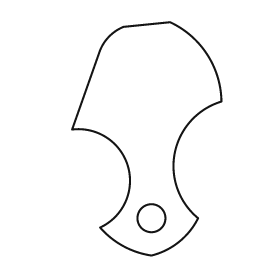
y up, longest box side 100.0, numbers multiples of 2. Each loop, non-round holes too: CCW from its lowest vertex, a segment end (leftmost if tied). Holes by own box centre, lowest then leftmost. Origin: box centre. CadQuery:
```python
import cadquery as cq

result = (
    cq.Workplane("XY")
    .moveTo(2.0, -50.0)
    .threePointArc((14.0, -44.0), (22.0, -34.0))
    .threePointArc((12.0, -6.0), (32.0, 16.0))
    .threePointArc((26.0, 36.0), (10.0, 50.0))
    .lineTo(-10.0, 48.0)
    .threePointArc((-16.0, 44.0), (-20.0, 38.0))
    .lineTo(-32.0, 4.0)
    .threePointArc((-8.0, -12.0), (-20.0, -38.0))
    .threePointArc((-10.0, -46.0), (2.0, -50.0))
    .close()
    .moveTo(2.0, -34.0)
    .circle(6.0)
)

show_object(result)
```